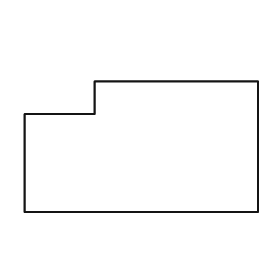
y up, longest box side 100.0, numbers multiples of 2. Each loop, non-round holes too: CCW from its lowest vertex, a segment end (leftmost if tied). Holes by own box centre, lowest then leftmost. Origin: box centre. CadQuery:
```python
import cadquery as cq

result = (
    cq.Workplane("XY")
    .moveTo(-50.0, -28.0)
    .lineTo(50.0, -28.0)
    .lineTo(50.0, 28.0)
    .lineTo(-20.0, 28.0)
    .lineTo(-20.0, 14.0)
    .lineTo(-50.0, 14.0)
    .close()
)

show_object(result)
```